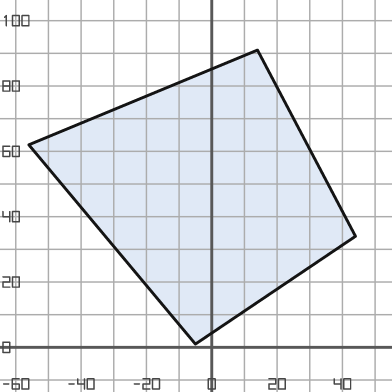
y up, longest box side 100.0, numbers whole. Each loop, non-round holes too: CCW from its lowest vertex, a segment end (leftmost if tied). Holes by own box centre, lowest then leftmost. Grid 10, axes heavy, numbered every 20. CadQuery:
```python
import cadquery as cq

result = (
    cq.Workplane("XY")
    .moveTo(-5.0, 1.0)
    .lineTo(44.0, 34.0)
    .lineTo(14.0, 91.0)
    .lineTo(-56.0, 62.0)
    .close()
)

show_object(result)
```